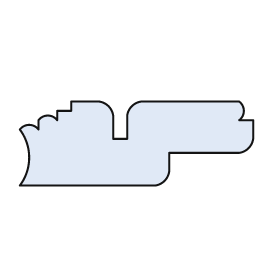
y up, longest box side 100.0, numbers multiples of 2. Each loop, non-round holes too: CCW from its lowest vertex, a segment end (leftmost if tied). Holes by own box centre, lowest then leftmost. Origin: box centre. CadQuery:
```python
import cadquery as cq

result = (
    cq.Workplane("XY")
    .moveTo(-50.0, -18.0)
    .lineTo(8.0, -18.0)
    .threePointArc((12.0, -16.0), (14.0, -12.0))
    .lineTo(14.0, -4.0)
    .lineTo(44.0, -4.0)
    .threePointArc((48.0, -2.0), (50.0, 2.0))
    .lineTo(50.0, 10.0)
    .lineTo(44.0, 10.0)
    .threePointArc((46.0, 14.0), (44.0, 18.0))
    .lineTo(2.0, 18.0)
    .threePointArc((-2.0, 16.0), (-4.0, 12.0))
    .lineTo(-4.0, 2.0)
    .lineTo(-10.0, 2.0)
    .lineTo(-10.0, 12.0)
    .threePointArc((-12.0, 16.0), (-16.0, 18.0))
    .lineTo(-28.0, 18.0)
    .lineTo(-28.0, 14.0)
    .lineTo(-34.0, 14.0)
    .lineTo(-34.0, 10.0)
    .threePointArc((-38.0, 12.0), (-42.0, 10.0))
    .lineTo(-42.0, 6.0)
    .threePointArc((-46.0, 8.0), (-50.0, 6.0))
    .threePointArc((-46.0, -6.0), (-50.0, -18.0))
    .close()
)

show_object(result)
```